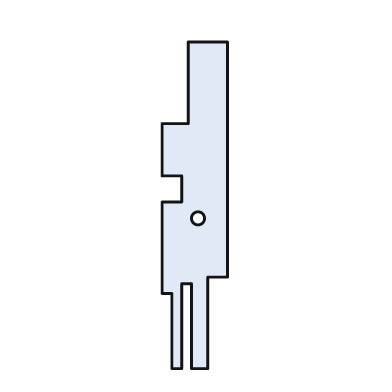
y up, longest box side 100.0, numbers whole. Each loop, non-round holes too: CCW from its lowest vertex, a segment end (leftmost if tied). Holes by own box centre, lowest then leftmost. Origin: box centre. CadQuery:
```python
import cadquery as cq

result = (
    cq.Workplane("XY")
    .moveTo(-7.0, -50.0)
    .lineTo(-4.0, -50.0)
    .lineTo(-4.0, -24.0)
    .lineTo(-1.0, -24.0)
    .lineTo(-1.0, -50.0)
    .lineTo(4.0, -50.0)
    .lineTo(4.0, -22.0)
    .lineTo(10.0, -22.0)
    .lineTo(10.0, 50.0)
    .lineTo(-2.0, 50.0)
    .lineTo(-2.0, 25.0)
    .lineTo(-10.0, 25.0)
    .lineTo(-10.0, 9.0)
    .lineTo(-4.0, 9.0)
    .lineTo(-4.0, 1.0)
    .lineTo(-10.0, 1.0)
    .lineTo(-10.0, -27.0)
    .lineTo(-7.0, -27.0)
    .close()
    .moveTo(1.0, -4.0)
    .circle(2.0)
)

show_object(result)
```